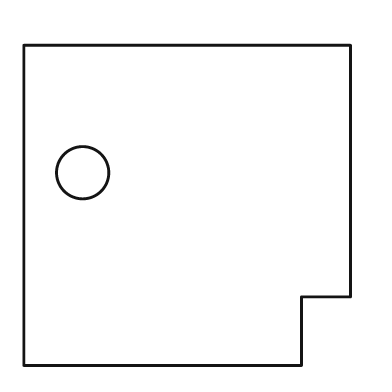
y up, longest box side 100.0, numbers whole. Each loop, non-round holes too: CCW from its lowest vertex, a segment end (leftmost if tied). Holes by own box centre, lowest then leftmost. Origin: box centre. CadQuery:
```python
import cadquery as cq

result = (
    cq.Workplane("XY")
    .moveTo(-50.0, -49.0)
    .lineTo(35.0, -49.0)
    .lineTo(35.0, -28.0)
    .lineTo(50.0, -28.0)
    .lineTo(50.0, 49.0)
    .lineTo(-50.0, 49.0)
    .close()
    .moveTo(-32.0, 10.0)
    .circle(8.0)
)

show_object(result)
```